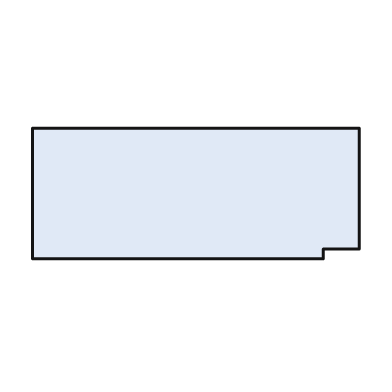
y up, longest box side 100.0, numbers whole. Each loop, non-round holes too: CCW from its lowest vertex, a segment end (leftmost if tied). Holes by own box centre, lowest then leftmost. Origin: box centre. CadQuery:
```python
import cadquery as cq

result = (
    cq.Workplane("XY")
    .moveTo(-50.0, -20.0)
    .lineTo(39.0, -20.0)
    .lineTo(39.0, -17.0)
    .lineTo(50.0, -17.0)
    .lineTo(50.0, 20.0)
    .lineTo(-50.0, 20.0)
    .close()
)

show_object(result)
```